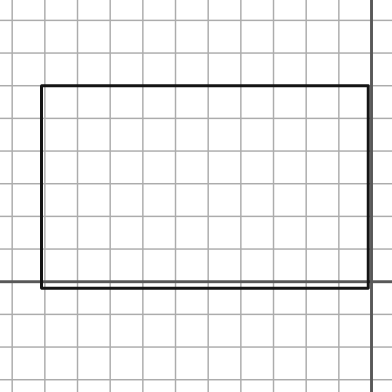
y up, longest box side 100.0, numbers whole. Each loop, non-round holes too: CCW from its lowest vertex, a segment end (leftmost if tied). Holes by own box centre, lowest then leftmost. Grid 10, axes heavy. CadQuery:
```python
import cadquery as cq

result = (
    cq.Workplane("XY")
    .moveTo(-101.0, -2.0)
    .lineTo(-1.0, -2.0)
    .lineTo(-1.0, 60.0)
    .lineTo(-101.0, 60.0)
    .close()
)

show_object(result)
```